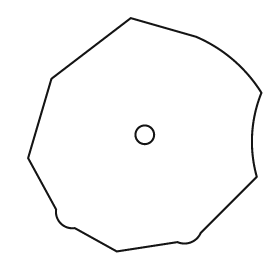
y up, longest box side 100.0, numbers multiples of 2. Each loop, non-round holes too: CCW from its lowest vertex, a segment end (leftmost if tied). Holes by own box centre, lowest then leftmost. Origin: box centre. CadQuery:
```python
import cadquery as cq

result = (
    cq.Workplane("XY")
    .moveTo(-12.0, -50.0)
    .lineTo(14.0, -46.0)
    .threePointArc((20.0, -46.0), (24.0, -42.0))
    .lineTo(48.0, -18.0)
    .threePointArc((46.0, 0.0), (50.0, 18.0))
    .threePointArc((38.0, 32.0), (22.0, 42.0))
    .lineTo(-6.0, 50.0)
    .lineTo(-40.0, 24.0)
    .lineTo(-50.0, -10.0)
    .lineTo(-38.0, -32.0)
    .threePointArc((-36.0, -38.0), (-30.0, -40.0))
    .close()
    .moveTo(0.0, 0.0)
    .circle(4.0)
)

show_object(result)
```